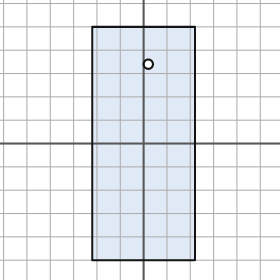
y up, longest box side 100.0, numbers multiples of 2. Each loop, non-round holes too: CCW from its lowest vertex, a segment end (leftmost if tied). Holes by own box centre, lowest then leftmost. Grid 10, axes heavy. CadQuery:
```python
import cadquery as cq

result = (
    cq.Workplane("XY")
    .moveTo(-22.0, -50.0)
    .lineTo(22.0, -50.0)
    .lineTo(22.0, 50.0)
    .lineTo(-22.0, 50.0)
    .close()
    .moveTo(2.0, 34.0)
    .circle(2.0)
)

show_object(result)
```